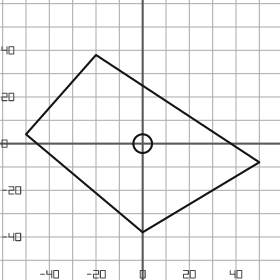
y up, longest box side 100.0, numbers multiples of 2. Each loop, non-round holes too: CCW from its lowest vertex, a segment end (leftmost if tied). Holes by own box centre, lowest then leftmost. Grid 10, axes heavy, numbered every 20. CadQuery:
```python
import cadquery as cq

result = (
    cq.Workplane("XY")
    .moveTo(0.0, -38.0)
    .lineTo(50.0, -8.0)
    .lineTo(-20.0, 38.0)
    .lineTo(-50.0, 4.0)
    .close()
    .moveTo(0.0, 0.0)
    .circle(4.0)
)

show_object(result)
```